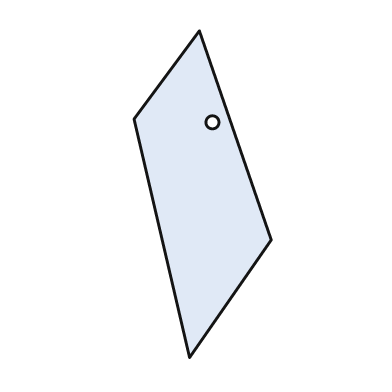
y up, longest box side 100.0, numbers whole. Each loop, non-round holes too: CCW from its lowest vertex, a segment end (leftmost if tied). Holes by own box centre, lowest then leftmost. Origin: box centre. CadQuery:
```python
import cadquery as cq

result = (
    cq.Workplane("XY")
    .moveTo(-4.0, -50.0)
    .lineTo(21.0, -14.0)
    .lineTo(-1.0, 50.0)
    .lineTo(-21.0, 23.0)
    .close()
    .moveTo(3.0, 22.0)
    .circle(2.0)
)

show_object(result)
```